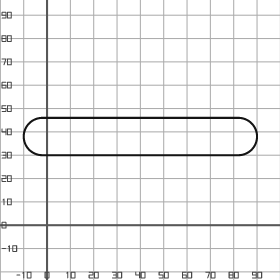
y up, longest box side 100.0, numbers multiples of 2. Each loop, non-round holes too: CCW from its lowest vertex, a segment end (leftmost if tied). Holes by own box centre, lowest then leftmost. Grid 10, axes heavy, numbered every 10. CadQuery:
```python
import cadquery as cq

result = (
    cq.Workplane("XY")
    .moveTo(-2.0, 30.0)
    .lineTo(82.0, 30.0)
    .threePointArc((90.0, 38.0), (82.0, 46.0))
    .lineTo(-2.0, 46.0)
    .threePointArc((-10.0, 38.0), (-2.0, 30.0))
    .close()
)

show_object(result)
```